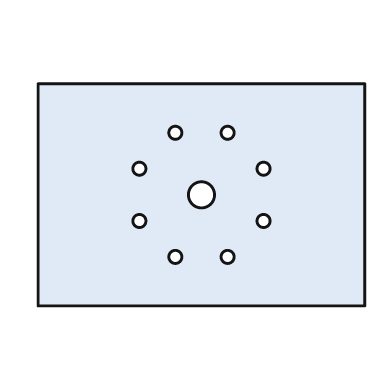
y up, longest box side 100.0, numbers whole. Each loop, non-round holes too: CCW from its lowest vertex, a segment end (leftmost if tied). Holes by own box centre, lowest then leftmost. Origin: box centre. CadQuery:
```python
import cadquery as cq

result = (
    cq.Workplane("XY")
    .moveTo(-50.0, -34.0)
    .lineTo(50.0, -34.0)
    .lineTo(50.0, 34.0)
    .lineTo(-50.0, 34.0)
    .close()
    .moveTo(-8.0, -19.0)
    .circle(2.0)
    .moveTo(8.0, -19.0)
    .circle(2.0)
    .moveTo(-19.0, -8.0)
    .circle(2.0)
    .moveTo(19.0, -8.0)
    .circle(2.0)
    .moveTo(0.0, 0.0)
    .circle(4.0)
    .moveTo(-19.0, 8.0)
    .circle(2.0)
    .moveTo(19.0, 8.0)
    .circle(2.0)
    .moveTo(-8.0, 19.0)
    .circle(2.0)
    .moveTo(8.0, 19.0)
    .circle(2.0)
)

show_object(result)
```